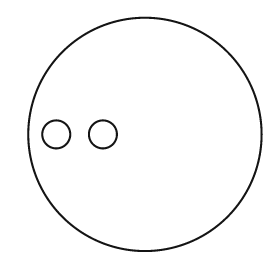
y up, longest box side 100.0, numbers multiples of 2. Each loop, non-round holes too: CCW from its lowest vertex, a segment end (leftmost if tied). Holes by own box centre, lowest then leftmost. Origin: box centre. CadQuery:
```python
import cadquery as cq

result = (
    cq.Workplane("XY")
    .moveTo(0.0, 0.0)
    .circle(50.0)
    .moveTo(-38.0, 0.0)
    .circle(6.0)
    .moveTo(-18.0, 0.0)
    .circle(6.0)
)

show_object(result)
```